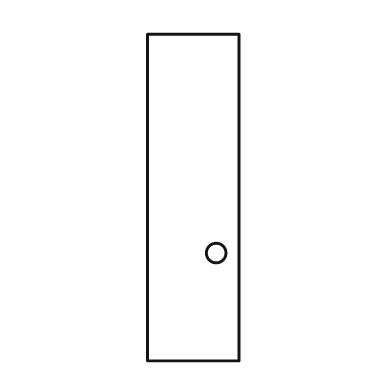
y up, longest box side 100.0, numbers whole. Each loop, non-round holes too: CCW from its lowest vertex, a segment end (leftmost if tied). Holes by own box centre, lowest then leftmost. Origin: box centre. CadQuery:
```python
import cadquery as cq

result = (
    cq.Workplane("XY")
    .moveTo(-14.0, -50.0)
    .lineTo(14.0, -50.0)
    .lineTo(14.0, 50.0)
    .lineTo(-14.0, 50.0)
    .close()
    .moveTo(7.0, -17.0)
    .circle(3.0)
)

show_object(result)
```